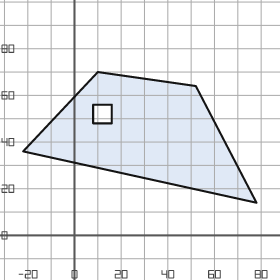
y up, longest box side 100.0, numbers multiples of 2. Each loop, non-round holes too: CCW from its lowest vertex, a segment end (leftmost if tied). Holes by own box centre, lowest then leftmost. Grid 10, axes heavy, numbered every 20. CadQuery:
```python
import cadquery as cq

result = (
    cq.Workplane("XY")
    .moveTo(78.0, 14.0)
    .lineTo(52.0, 64.0)
    .lineTo(10.0, 70.0)
    .lineTo(-22.0, 36.0)
    .close()
    .moveTo(8.0, 48.0)
    .lineTo(16.0, 48.0)
    .lineTo(16.0, 56.0)
    .lineTo(8.0, 56.0)
    .close()
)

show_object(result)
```